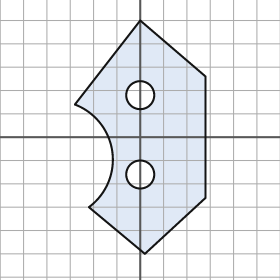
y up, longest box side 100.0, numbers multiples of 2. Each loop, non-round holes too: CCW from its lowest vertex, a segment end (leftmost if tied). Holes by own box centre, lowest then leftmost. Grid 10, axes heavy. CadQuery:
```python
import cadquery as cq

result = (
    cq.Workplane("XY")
    .moveTo(2.0, -50.0)
    .lineTo(28.0, -26.0)
    .lineTo(28.0, 26.0)
    .lineTo(0.0, 50.0)
    .lineTo(-28.0, 14.0)
    .threePointArc((-12.0, -6.0), (-22.0, -30.0))
    .close()
    .moveTo(0.0, -16.0)
    .circle(6.0)
    .moveTo(0.0, 18.0)
    .circle(6.0)
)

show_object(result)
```